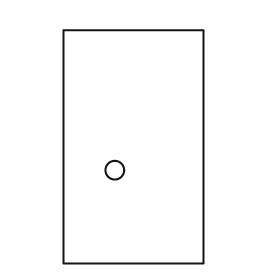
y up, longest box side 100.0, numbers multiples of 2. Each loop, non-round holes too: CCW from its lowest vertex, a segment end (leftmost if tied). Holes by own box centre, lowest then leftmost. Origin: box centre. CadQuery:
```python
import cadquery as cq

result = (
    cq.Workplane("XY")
    .moveTo(-30.0, -50.0)
    .lineTo(30.0, -50.0)
    .lineTo(30.0, 50.0)
    .lineTo(-30.0, 50.0)
    .close()
    .moveTo(-8.0, -10.0)
    .circle(4.0)
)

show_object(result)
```